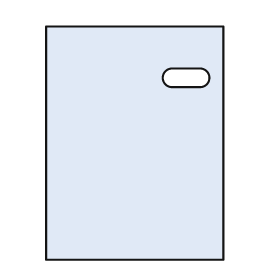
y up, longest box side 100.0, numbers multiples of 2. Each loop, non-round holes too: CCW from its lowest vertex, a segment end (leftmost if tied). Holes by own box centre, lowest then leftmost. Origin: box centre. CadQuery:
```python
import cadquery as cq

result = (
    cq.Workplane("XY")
    .moveTo(-38.0, -50.0)
    .lineTo(38.0, -50.0)
    .lineTo(38.0, 50.0)
    .lineTo(-38.0, 50.0)
    .close()
    .moveTo(16.0, 24.0)
    .lineTo(28.0, 24.0)
    .threePointArc((32.0, 28.0), (28.0, 32.0))
    .lineTo(16.0, 32.0)
    .threePointArc((12.0, 28.0), (16.0, 24.0))
    .close()
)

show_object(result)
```